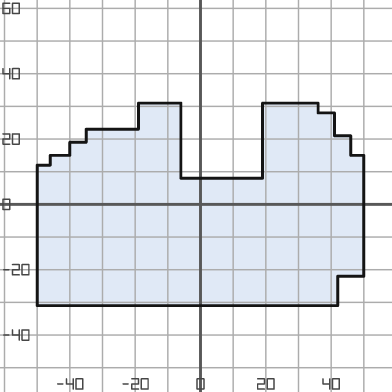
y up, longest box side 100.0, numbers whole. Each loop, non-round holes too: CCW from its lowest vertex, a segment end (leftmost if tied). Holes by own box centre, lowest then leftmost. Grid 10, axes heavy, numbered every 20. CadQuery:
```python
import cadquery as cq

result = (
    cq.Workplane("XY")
    .moveTo(-50.0, -31.0)
    .lineTo(42.0, -31.0)
    .lineTo(42.0, -22.0)
    .lineTo(50.0, -22.0)
    .lineTo(50.0, 15.0)
    .lineTo(46.0, 15.0)
    .lineTo(46.0, 21.0)
    .lineTo(41.0, 21.0)
    .lineTo(41.0, 28.0)
    .lineTo(36.0, 28.0)
    .lineTo(36.0, 31.0)
    .lineTo(19.0, 31.0)
    .lineTo(19.0, 8.0)
    .lineTo(-6.0, 8.0)
    .lineTo(-6.0, 31.0)
    .lineTo(-19.0, 31.0)
    .lineTo(-19.0, 23.0)
    .lineTo(-35.0, 23.0)
    .lineTo(-35.0, 19.0)
    .lineTo(-40.0, 19.0)
    .lineTo(-40.0, 15.0)
    .lineTo(-46.0, 15.0)
    .lineTo(-46.0, 12.0)
    .lineTo(-50.0, 12.0)
    .close()
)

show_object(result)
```